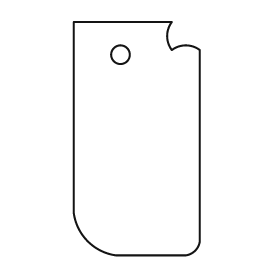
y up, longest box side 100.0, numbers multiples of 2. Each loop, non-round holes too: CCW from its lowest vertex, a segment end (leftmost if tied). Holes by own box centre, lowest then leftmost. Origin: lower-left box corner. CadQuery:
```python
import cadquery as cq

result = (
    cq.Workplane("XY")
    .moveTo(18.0, 0.0)
    .lineTo(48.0, 0.0)
    .threePointArc((52.0, 2.0), (54.0, 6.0))
    .lineTo(54.0, 88.0)
    .threePointArc((48.0, 90.0), (42.0, 88.0))
    .threePointArc((40.0, 94.0), (42.0, 100.0))
    .lineTo(0.0, 100.0)
    .lineTo(0.0, 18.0)
    .threePointArc((6.0, 6.0), (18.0, 0.0))
    .close()
    .moveTo(20.0, 86.0)
    .circle(4.0)
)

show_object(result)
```